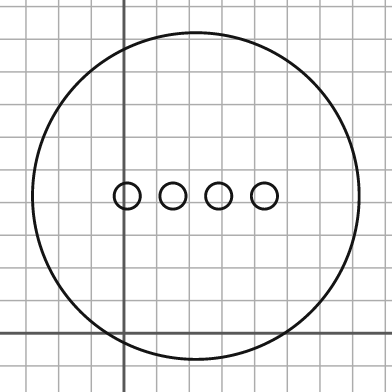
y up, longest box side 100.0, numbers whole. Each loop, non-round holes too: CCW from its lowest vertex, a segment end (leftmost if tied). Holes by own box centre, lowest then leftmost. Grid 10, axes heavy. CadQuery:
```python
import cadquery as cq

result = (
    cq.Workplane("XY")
    .moveTo(22.0, 42.0)
    .circle(50.0)
    .moveTo(1.0, 42.0)
    .circle(4.0)
    .moveTo(15.0, 42.0)
    .circle(4.0)
    .moveTo(29.0, 42.0)
    .circle(4.0)
    .moveTo(43.0, 42.0)
    .circle(4.0)
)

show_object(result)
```